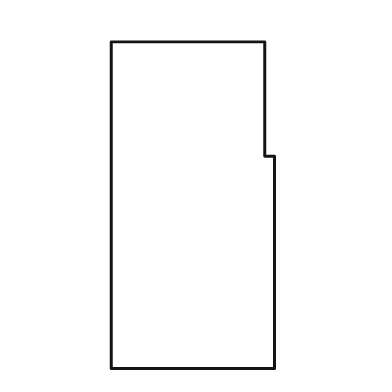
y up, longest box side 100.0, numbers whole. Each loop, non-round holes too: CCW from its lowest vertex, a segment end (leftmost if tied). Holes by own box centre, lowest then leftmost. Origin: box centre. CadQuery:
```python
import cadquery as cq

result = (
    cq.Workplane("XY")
    .moveTo(-25.0, -50.0)
    .lineTo(25.0, -50.0)
    .lineTo(25.0, 15.0)
    .lineTo(22.0, 15.0)
    .lineTo(22.0, 50.0)
    .lineTo(-25.0, 50.0)
    .close()
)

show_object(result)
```